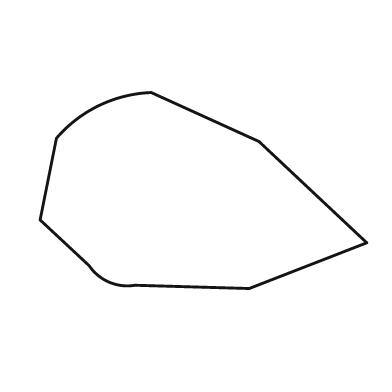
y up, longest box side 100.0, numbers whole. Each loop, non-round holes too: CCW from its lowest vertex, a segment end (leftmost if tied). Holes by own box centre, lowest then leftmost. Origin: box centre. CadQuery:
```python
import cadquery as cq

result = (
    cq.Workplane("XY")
    .moveTo(14.0, -30.0)
    .lineTo(50.0, -16.0)
    .lineTo(17.0, 15.0)
    .lineTo(-16.0, 30.0)
    .threePointArc((-32.0, 26.0), (-45.0, 16.0))
    .lineTo(-50.0, -9.0)
    .lineTo(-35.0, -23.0)
    .threePointArc((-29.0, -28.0), (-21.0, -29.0))
    .close()
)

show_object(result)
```